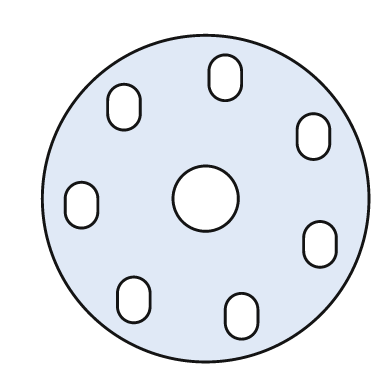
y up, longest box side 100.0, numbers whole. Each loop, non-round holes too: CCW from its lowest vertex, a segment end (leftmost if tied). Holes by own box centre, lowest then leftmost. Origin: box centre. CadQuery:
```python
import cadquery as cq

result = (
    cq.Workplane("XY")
    .moveTo(0.0, 0.0)
    .circle(50.0)
    .moveTo(6.0, -38.0)
    .threePointArc((11.0, -43.0), (16.0, -38.0))
    .lineTo(16.0, -34.0)
    .threePointArc((11.0, -29.0), (6.0, -34.0))
    .close()
    .moveTo(-27.0, -33.0)
    .threePointArc((-22.0, -38.0), (-17.0, -33.0))
    .lineTo(-17.0, -29.0)
    .threePointArc((-22.0, -24.0), (-27.0, -29.0))
    .close()
    .moveTo(30.0, -16.0)
    .threePointArc((35.0, -21.0), (40.0, -16.0))
    .lineTo(40.0, -12.0)
    .threePointArc((35.0, -7.0), (30.0, -12.0))
    .close()
    .moveTo(-43.0, -4.0)
    .threePointArc((-38.0, -9.0), (-33.0, -4.0))
    .lineTo(-33.0, 0.0)
    .threePointArc((-38.0, 5.0), (-43.0, 0.0))
    .close()
    .moveTo(0.0, 0.0)
    .circle(10.0)
    .moveTo(28.0, 17.0)
    .threePointArc((33.0, 12.0), (38.0, 17.0))
    .lineTo(38.0, 21.0)
    .threePointArc((33.0, 26.0), (28.0, 21.0))
    .close()
    .moveTo(-30.0, 26.0)
    .threePointArc((-25.0, 21.0), (-20.0, 26.0))
    .lineTo(-20.0, 30.0)
    .threePointArc((-25.0, 35.0), (-30.0, 30.0))
    .close()
    .moveTo(1.0, 35.0)
    .threePointArc((6.0, 30.0), (11.0, 35.0))
    .lineTo(11.0, 39.0)
    .threePointArc((6.0, 44.0), (1.0, 39.0))
    .close()
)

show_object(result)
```